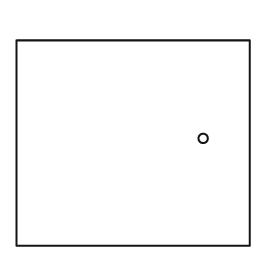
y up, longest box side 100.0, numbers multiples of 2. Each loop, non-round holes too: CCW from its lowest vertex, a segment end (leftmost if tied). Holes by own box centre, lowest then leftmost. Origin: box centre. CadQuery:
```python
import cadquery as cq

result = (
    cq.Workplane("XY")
    .moveTo(-50.0, -44.0)
    .lineTo(50.0, -44.0)
    .lineTo(50.0, 44.0)
    .lineTo(-50.0, 44.0)
    .close()
    .moveTo(30.0, 2.0)
    .circle(2.0)
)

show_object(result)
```